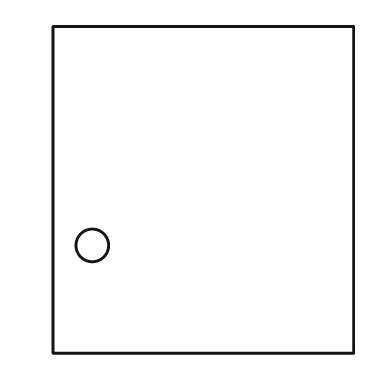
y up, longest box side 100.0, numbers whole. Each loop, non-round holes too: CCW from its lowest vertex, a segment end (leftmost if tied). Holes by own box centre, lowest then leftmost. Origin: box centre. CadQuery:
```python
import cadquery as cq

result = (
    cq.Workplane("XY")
    .moveTo(-46.0, -50.0)
    .lineTo(46.0, -50.0)
    .lineTo(46.0, 50.0)
    .lineTo(-46.0, 50.0)
    .close()
    .moveTo(-34.0, -17.0)
    .circle(5.0)
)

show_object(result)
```